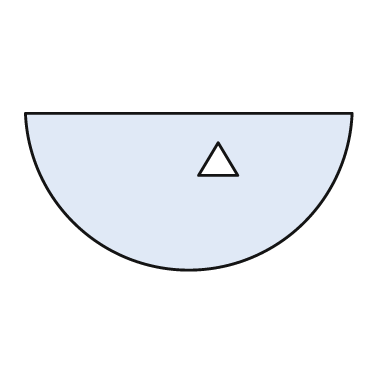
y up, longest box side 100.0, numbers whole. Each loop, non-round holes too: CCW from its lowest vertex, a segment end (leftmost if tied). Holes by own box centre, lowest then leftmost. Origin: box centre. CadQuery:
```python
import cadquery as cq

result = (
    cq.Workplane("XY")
    .moveTo(-50.0, 24.0)
    .threePointArc((0.0, -24.0), (50.0, 24.0))
    .close()
    .moveTo(3.0, 5.0)
    .lineTo(15.0, 5.0)
    .lineTo(9.0, 15.0)
    .close()
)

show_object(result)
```